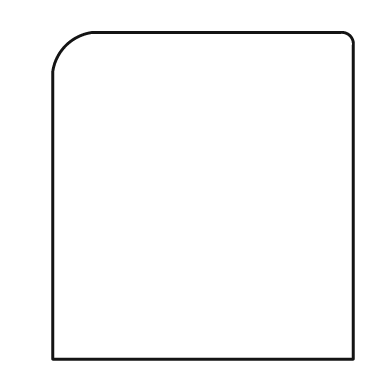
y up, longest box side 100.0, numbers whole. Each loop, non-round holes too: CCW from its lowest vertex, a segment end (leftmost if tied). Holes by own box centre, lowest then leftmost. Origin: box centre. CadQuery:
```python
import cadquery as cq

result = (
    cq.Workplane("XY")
    .moveTo(-46.0, -50.0)
    .lineTo(46.0, -50.0)
    .lineTo(46.0, 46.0)
    .threePointArc((45.0, 49.0), (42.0, 50.0))
    .lineTo(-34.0, 50.0)
    .threePointArc((-42.0, 46.0), (-46.0, 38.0))
    .close()
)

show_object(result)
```